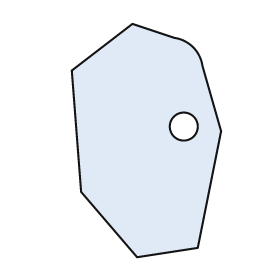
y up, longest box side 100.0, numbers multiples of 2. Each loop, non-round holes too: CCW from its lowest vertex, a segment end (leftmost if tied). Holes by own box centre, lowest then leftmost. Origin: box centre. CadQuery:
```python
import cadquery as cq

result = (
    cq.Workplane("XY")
    .moveTo(-4.0, -50.0)
    .lineTo(22.0, -46.0)
    .lineTo(32.0, 4.0)
    .lineTo(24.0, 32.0)
    .threePointArc((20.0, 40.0), (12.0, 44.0))
    .lineTo(-6.0, 50.0)
    .lineTo(-32.0, 30.0)
    .lineTo(-28.0, -22.0)
    .close()
    .moveTo(16.0, 6.0)
    .circle(6.0)
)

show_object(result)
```